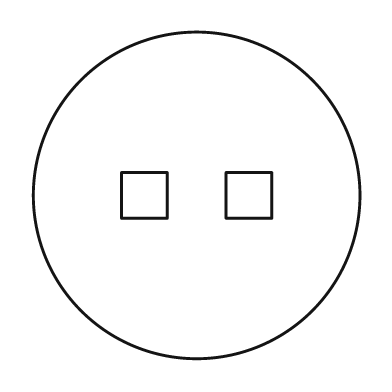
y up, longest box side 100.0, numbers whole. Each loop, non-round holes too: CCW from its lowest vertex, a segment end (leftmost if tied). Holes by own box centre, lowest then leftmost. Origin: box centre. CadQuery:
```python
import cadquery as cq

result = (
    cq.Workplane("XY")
    .moveTo(0.0, 0.0)
    .circle(50.0)
    .moveTo(-23.0, -7.0)
    .lineTo(-9.0, -7.0)
    .lineTo(-9.0, 7.0)
    .lineTo(-23.0, 7.0)
    .close()
    .moveTo(9.0, -7.0)
    .lineTo(23.0, -7.0)
    .lineTo(23.0, 7.0)
    .lineTo(9.0, 7.0)
    .close()
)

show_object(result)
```